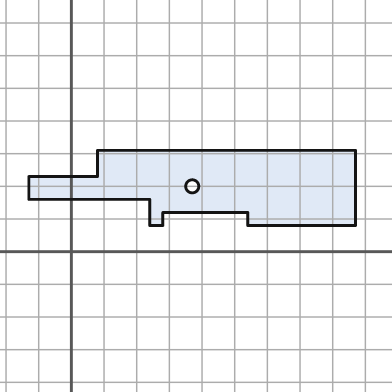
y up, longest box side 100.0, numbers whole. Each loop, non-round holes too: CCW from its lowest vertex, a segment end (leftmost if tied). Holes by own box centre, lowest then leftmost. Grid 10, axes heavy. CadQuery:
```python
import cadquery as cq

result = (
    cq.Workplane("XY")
    .moveTo(24.0, 8.0)
    .lineTo(28.0, 8.0)
    .lineTo(28.0, 12.0)
    .lineTo(54.0, 12.0)
    .lineTo(54.0, 8.0)
    .lineTo(87.0, 8.0)
    .lineTo(87.0, 31.0)
    .lineTo(8.0, 31.0)
    .lineTo(8.0, 23.0)
    .lineTo(-13.0, 23.0)
    .lineTo(-13.0, 16.0)
    .lineTo(24.0, 16.0)
    .close()
    .moveTo(37.0, 20.0)
    .circle(2.0)
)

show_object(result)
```